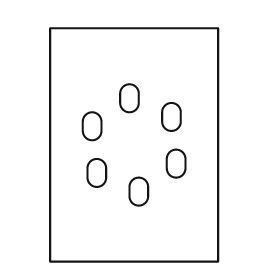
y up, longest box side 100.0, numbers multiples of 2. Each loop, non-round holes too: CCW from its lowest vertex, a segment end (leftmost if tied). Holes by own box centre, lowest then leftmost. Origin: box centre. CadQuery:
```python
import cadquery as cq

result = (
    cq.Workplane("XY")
    .moveTo(-36.0, -50.0)
    .lineTo(36.0, -50.0)
    .lineTo(36.0, 50.0)
    .lineTo(-36.0, 50.0)
    .close()
    .moveTo(-2.0, -22.0)
    .threePointArc((2.0, -26.0), (6.0, -22.0))
    .lineTo(6.0, -18.0)
    .threePointArc((2.0, -14.0), (-2.0, -18.0))
    .close()
    .moveTo(-20.0, -14.0)
    .threePointArc((-16.0, -18.0), (-12.0, -14.0))
    .lineTo(-12.0, -10.0)
    .threePointArc((-16.0, -6.0), (-20.0, -10.0))
    .close()
    .moveTo(14.0, -10.0)
    .threePointArc((18.0, -14.0), (22.0, -10.0))
    .lineTo(22.0, -6.0)
    .threePointArc((18.0, -2.0), (14.0, -6.0))
    .close()
    .moveTo(-22.0, 6.0)
    .threePointArc((-18.0, 2.0), (-14.0, 6.0))
    .lineTo(-14.0, 10.0)
    .threePointArc((-18.0, 14.0), (-22.0, 10.0))
    .close()
    .moveTo(12.0, 10.0)
    .threePointArc((16.0, 6.0), (20.0, 10.0))
    .lineTo(20.0, 14.0)
    .threePointArc((16.0, 18.0), (12.0, 14.0))
    .close()
    .moveTo(-6.0, 18.0)
    .threePointArc((-2.0, 14.0), (2.0, 18.0))
    .lineTo(2.0, 22.0)
    .threePointArc((-2.0, 26.0), (-6.0, 22.0))
    .close()
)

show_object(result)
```